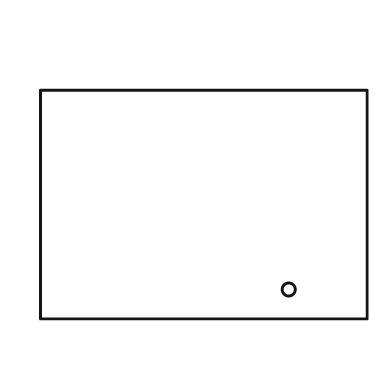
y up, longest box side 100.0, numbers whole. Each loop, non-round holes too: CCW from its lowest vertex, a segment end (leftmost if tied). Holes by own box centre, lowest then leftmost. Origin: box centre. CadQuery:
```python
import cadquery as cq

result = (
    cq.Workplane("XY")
    .moveTo(-50.0, -35.0)
    .lineTo(50.0, -35.0)
    .lineTo(50.0, 35.0)
    .lineTo(-50.0, 35.0)
    .close()
    .moveTo(26.0, -26.0)
    .circle(2.0)
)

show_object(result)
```